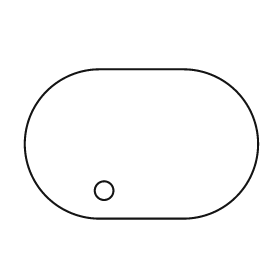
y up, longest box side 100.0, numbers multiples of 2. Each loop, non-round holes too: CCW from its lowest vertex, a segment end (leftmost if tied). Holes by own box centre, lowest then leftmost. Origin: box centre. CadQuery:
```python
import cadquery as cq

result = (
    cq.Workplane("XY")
    .moveTo(-18.0, -32.0)
    .lineTo(18.0, -32.0)
    .threePointArc((50.0, 0.0), (18.0, 32.0))
    .lineTo(-18.0, 32.0)
    .threePointArc((-50.0, 0.0), (-18.0, -32.0))
    .close()
    .moveTo(-16.0, -20.0)
    .circle(4.0)
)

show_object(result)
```